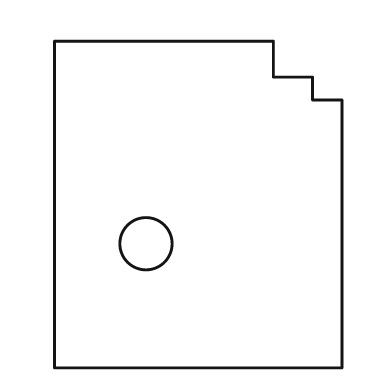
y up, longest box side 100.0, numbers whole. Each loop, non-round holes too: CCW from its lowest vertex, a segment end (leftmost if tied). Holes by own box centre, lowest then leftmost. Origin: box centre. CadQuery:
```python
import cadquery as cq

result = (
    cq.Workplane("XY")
    .moveTo(-44.0, -50.0)
    .lineTo(44.0, -50.0)
    .lineTo(44.0, 32.0)
    .lineTo(35.0, 32.0)
    .lineTo(35.0, 39.0)
    .lineTo(23.0, 39.0)
    .lineTo(23.0, 50.0)
    .lineTo(-44.0, 50.0)
    .close()
    .moveTo(-16.0, -12.0)
    .circle(8.0)
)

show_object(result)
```